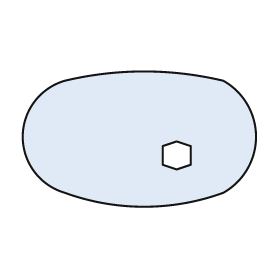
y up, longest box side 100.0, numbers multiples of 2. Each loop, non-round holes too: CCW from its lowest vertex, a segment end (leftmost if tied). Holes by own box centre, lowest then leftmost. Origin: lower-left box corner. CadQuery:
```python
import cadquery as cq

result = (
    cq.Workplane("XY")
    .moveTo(18.0, 6.0)
    .threePointArc((52.0, 0.0), (86.0, 6.0))
    .threePointArc((100.0, 30.0), (86.0, 54.0))
    .threePointArc((52.0, 58.0), (18.0, 54.0))
    .threePointArc((0.0, 30.0), (18.0, 6.0))
    .close()
    .moveTo(66.0, 16.0)
    .lineTo(72.0, 18.0)
    .lineTo(72.0, 26.0)
    .lineTo(66.0, 28.0)
    .lineTo(60.0, 26.0)
    .lineTo(60.0, 18.0)
    .close()
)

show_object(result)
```